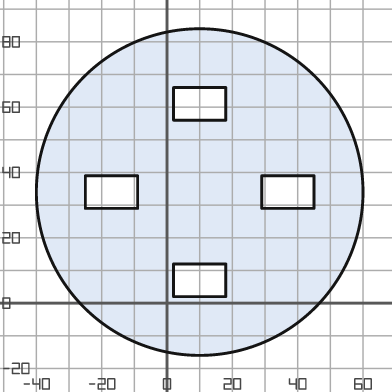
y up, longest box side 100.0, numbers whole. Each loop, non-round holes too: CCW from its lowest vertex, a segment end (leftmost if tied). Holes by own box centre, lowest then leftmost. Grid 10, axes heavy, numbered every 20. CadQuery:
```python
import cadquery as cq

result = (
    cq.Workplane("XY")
    .moveTo(10.0, 34.0)
    .circle(50.0)
    .moveTo(2.0, 2.0)
    .lineTo(18.0, 2.0)
    .lineTo(18.0, 12.0)
    .lineTo(2.0, 12.0)
    .close()
    .moveTo(-25.0, 29.0)
    .lineTo(-9.0, 29.0)
    .lineTo(-9.0, 39.0)
    .lineTo(-25.0, 39.0)
    .close()
    .moveTo(29.0, 29.0)
    .lineTo(45.0, 29.0)
    .lineTo(45.0, 39.0)
    .lineTo(29.0, 39.0)
    .close()
    .moveTo(2.0, 56.0)
    .lineTo(18.0, 56.0)
    .lineTo(18.0, 66.0)
    .lineTo(2.0, 66.0)
    .close()
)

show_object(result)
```